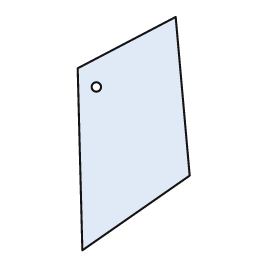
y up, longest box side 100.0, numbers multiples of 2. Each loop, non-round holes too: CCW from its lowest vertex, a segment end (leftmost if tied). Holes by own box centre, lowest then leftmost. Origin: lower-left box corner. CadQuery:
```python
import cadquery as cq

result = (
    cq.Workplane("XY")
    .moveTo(2.0, 0.0)
    .lineTo(48.0, 32.0)
    .lineTo(42.0, 100.0)
    .lineTo(0.0, 78.0)
    .close()
    .moveTo(8.0, 70.0)
    .circle(2.0)
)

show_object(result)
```